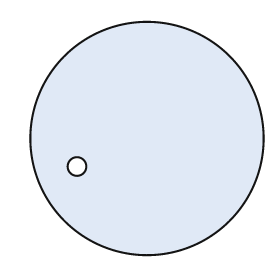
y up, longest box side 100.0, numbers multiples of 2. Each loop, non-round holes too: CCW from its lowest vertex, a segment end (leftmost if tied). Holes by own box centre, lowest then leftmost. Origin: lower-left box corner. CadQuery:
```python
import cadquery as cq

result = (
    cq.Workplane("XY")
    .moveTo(50.0, 50.0)
    .circle(50.0)
    .moveTo(20.0, 38.0)
    .circle(4.0)
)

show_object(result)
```